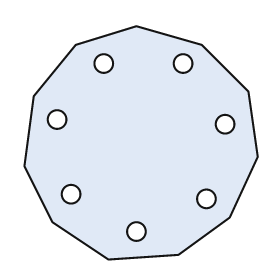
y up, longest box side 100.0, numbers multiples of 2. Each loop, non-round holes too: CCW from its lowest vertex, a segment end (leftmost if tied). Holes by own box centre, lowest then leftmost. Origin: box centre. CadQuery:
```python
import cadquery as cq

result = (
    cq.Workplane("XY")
    .moveTo(-14.0, -50.0)
    .lineTo(16.0, -48.0)
    .lineTo(38.0, -32.0)
    .lineTo(50.0, -6.0)
    .lineTo(46.0, 22.0)
    .lineTo(26.0, 42.0)
    .lineTo(-2.0, 50.0)
    .lineTo(-28.0, 42.0)
    .lineTo(-46.0, 20.0)
    .lineTo(-50.0, -10.0)
    .lineTo(-38.0, -34.0)
    .close()
    .moveTo(-2.0, -38.0)
    .circle(4.0)
    .moveTo(28.0, -24.0)
    .circle(4.0)
    .moveTo(-30.0, -22.0)
    .circle(4.0)
    .moveTo(36.0, 8.0)
    .circle(4.0)
    .moveTo(-36.0, 10.0)
    .circle(4.0)
    .moveTo(-16.0, 34.0)
    .circle(4.0)
    .moveTo(18.0, 34.0)
    .circle(4.0)
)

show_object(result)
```